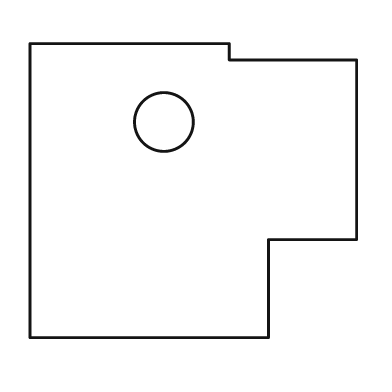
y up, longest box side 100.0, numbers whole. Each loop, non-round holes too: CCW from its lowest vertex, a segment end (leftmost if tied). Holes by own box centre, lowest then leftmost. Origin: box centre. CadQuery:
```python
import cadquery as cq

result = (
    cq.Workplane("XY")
    .moveTo(-50.0, -45.0)
    .lineTo(23.0, -45.0)
    .lineTo(23.0, -15.0)
    .lineTo(50.0, -15.0)
    .lineTo(50.0, 40.0)
    .lineTo(11.0, 40.0)
    .lineTo(11.0, 45.0)
    .lineTo(-50.0, 45.0)
    .close()
    .moveTo(-9.0, 21.0)
    .circle(9.0)
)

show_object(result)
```